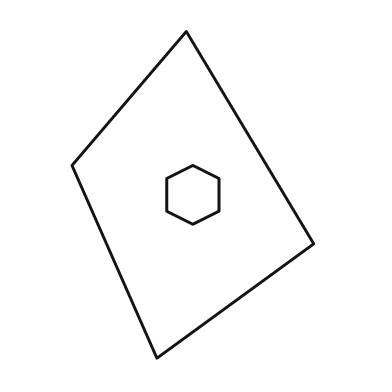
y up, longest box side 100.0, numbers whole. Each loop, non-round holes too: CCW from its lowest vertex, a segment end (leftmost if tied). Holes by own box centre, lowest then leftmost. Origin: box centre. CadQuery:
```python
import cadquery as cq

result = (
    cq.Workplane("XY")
    .moveTo(-11.0, -50.0)
    .lineTo(37.0, -15.0)
    .lineTo(-2.0, 50.0)
    .lineTo(-37.0, 9.0)
    .close()
    .moveTo(0.0, -9.0)
    .lineTo(8.0, -5.0)
    .lineTo(8.0, 5.0)
    .lineTo(0.0, 9.0)
    .lineTo(-8.0, 5.0)
    .lineTo(-8.0, -5.0)
    .close()
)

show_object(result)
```